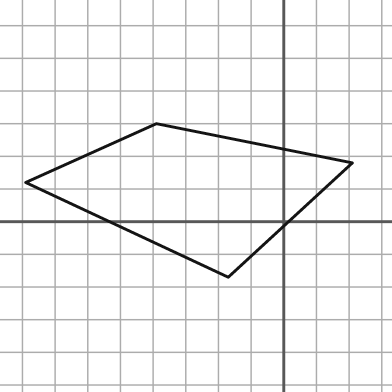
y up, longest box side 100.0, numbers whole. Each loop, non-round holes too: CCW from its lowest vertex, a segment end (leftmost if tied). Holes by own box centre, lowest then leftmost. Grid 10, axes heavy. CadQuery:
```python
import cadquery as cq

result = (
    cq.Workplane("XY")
    .moveTo(-17.0, -17.0)
    .lineTo(21.0, 18.0)
    .lineTo(-39.0, 30.0)
    .lineTo(-79.0, 12.0)
    .close()
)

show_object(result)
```